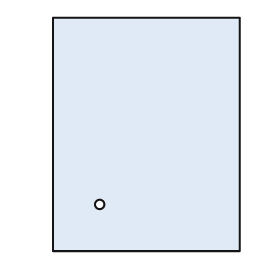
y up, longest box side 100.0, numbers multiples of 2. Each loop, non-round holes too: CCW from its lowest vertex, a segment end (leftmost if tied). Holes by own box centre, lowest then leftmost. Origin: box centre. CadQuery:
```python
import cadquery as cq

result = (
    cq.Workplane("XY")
    .moveTo(-40.0, -50.0)
    .lineTo(40.0, -50.0)
    .lineTo(40.0, 50.0)
    .lineTo(-40.0, 50.0)
    .close()
    .moveTo(-20.0, -30.0)
    .circle(2.0)
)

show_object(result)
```